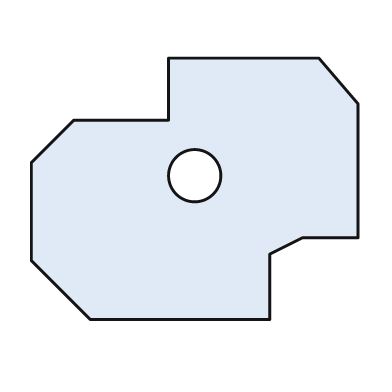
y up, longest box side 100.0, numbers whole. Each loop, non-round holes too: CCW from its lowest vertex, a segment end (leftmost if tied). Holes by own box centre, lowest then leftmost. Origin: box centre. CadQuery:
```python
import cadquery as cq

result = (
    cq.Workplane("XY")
    .moveTo(-32.0, -40.0)
    .lineTo(23.0, -40.0)
    .lineTo(23.0, -20.0)
    .lineTo(33.0, -15.0)
    .lineTo(50.0, -15.0)
    .lineTo(50.0, 26.0)
    .lineTo(38.0, 40.0)
    .lineTo(-8.0, 40.0)
    .lineTo(-8.0, 21.0)
    .lineTo(-37.0, 21.0)
    .lineTo(-50.0, 8.0)
    .lineTo(-50.0, -22.0)
    .close()
    .moveTo(0.0, 4.0)
    .circle(8.0)
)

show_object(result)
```